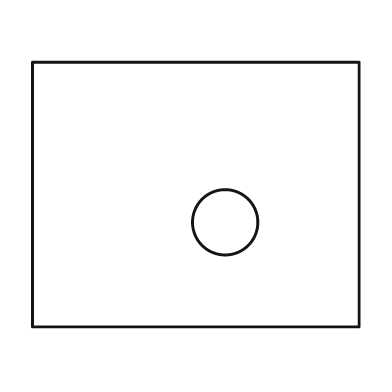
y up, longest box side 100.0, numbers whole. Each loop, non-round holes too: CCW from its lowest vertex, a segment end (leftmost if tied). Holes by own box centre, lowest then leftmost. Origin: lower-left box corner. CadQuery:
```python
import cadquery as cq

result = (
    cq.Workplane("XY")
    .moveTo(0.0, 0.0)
    .lineTo(100.0, 0.0)
    .lineTo(100.0, 81.0)
    .lineTo(0.0, 81.0)
    .close()
    .moveTo(59.0, 32.0)
    .circle(10.0)
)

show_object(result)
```